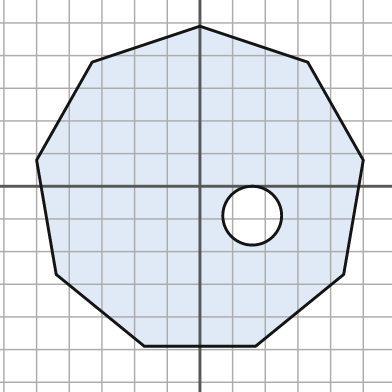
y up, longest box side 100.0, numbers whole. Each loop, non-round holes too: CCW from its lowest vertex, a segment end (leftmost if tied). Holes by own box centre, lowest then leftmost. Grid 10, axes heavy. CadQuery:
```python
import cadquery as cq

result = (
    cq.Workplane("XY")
    .moveTo(-17.0, -49.0)
    .lineTo(17.0, -49.0)
    .lineTo(44.0, -27.0)
    .lineTo(50.0, 8.0)
    .lineTo(33.0, 38.0)
    .lineTo(0.0, 49.0)
    .lineTo(-33.0, 38.0)
    .lineTo(-50.0, 8.0)
    .lineTo(-44.0, -27.0)
    .close()
    .moveTo(16.0, -9.0)
    .circle(9.0)
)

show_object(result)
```